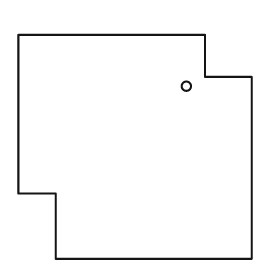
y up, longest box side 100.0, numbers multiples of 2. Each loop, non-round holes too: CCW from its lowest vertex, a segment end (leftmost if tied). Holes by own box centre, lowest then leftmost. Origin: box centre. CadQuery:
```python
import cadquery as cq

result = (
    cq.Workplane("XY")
    .moveTo(-34.0, -48.0)
    .lineTo(50.0, -48.0)
    .lineTo(50.0, 30.0)
    .lineTo(30.0, 30.0)
    .lineTo(30.0, 48.0)
    .lineTo(-50.0, 48.0)
    .lineTo(-50.0, -20.0)
    .lineTo(-34.0, -20.0)
    .close()
    .moveTo(22.0, 26.0)
    .circle(2.0)
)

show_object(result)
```